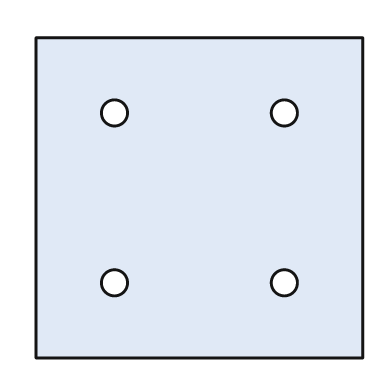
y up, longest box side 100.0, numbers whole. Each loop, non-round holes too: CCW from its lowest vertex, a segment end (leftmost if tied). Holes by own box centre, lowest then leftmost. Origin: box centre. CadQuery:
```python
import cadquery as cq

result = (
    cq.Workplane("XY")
    .moveTo(-50.0, -49.0)
    .lineTo(50.0, -49.0)
    .lineTo(50.0, 49.0)
    .lineTo(-50.0, 49.0)
    .close()
    .moveTo(-26.0, -26.0)
    .circle(4.0)
    .moveTo(26.0, -26.0)
    .circle(4.0)
    .moveTo(-26.0, 26.0)
    .circle(4.0)
    .moveTo(26.0, 26.0)
    .circle(4.0)
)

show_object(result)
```